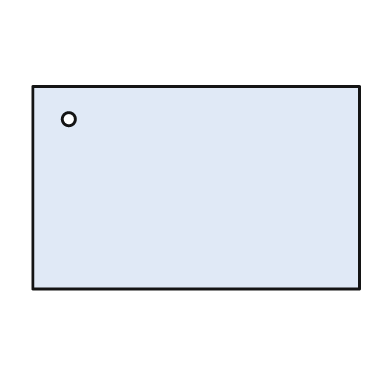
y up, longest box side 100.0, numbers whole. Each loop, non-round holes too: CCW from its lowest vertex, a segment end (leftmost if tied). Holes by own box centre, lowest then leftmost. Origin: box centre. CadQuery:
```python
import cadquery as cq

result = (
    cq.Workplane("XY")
    .moveTo(-50.0, -31.0)
    .lineTo(50.0, -31.0)
    .lineTo(50.0, 31.0)
    .lineTo(-50.0, 31.0)
    .close()
    .moveTo(-39.0, 21.0)
    .circle(2.0)
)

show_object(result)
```